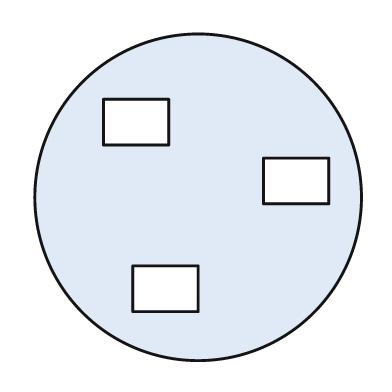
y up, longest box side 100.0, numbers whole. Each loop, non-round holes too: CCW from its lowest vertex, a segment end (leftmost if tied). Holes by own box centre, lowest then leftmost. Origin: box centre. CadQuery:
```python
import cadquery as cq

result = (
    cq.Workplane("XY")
    .moveTo(0.0, 0.0)
    .circle(50.0)
    .moveTo(-20.0, -35.0)
    .lineTo(0.0, -35.0)
    .lineTo(0.0, -21.0)
    .lineTo(-20.0, -21.0)
    .close()
    .moveTo(20.0, -2.0)
    .lineTo(40.0, -2.0)
    .lineTo(40.0, 12.0)
    .lineTo(20.0, 12.0)
    .close()
    .moveTo(-29.0, 16.0)
    .lineTo(-9.0, 16.0)
    .lineTo(-9.0, 30.0)
    .lineTo(-29.0, 30.0)
    .close()
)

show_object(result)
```